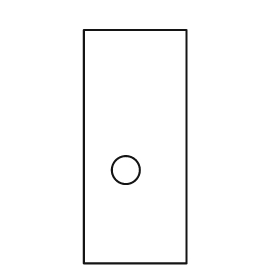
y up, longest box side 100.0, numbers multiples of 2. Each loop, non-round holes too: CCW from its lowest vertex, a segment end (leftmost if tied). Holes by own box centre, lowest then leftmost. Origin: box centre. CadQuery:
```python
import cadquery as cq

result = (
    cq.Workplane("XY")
    .moveTo(-22.0, -50.0)
    .lineTo(22.0, -50.0)
    .lineTo(22.0, 50.0)
    .lineTo(-22.0, 50.0)
    .close()
    .moveTo(-4.0, -10.0)
    .circle(6.0)
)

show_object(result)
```